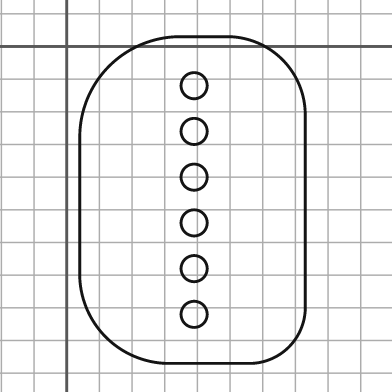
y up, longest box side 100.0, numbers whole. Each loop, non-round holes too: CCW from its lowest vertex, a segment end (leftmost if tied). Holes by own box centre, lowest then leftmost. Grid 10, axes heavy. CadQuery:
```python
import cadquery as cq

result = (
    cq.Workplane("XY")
    .moveTo(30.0, -97.0)
    .lineTo(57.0, -97.0)
    .threePointArc((68.0, -92.0), (73.0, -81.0))
    .lineTo(73.0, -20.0)
    .threePointArc((66.0, -4.0), (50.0, 3.0))
    .lineTo(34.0, 3.0)
    .threePointArc((13.0, -6.0), (4.0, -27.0))
    .lineTo(4.0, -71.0)
    .threePointArc((12.0, -89.0), (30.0, -97.0))
    .close()
    .moveTo(39.0, -82.0)
    .circle(4.0)
    .moveTo(39.0, -68.0)
    .circle(4.0)
    .moveTo(39.0, -54.0)
    .circle(4.0)
    .moveTo(39.0, -40.0)
    .circle(4.0)
    .moveTo(39.0, -26.0)
    .circle(4.0)
    .moveTo(39.0, -12.0)
    .circle(4.0)
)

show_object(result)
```